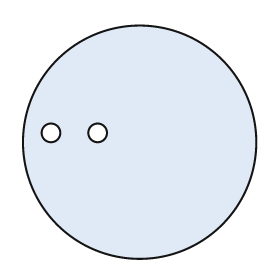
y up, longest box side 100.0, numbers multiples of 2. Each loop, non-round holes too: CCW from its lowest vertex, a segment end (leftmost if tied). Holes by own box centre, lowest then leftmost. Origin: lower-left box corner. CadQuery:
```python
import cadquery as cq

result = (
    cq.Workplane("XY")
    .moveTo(50.0, 50.0)
    .circle(50.0)
    .moveTo(12.0, 54.0)
    .circle(4.0)
    .moveTo(32.0, 54.0)
    .circle(4.0)
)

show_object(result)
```